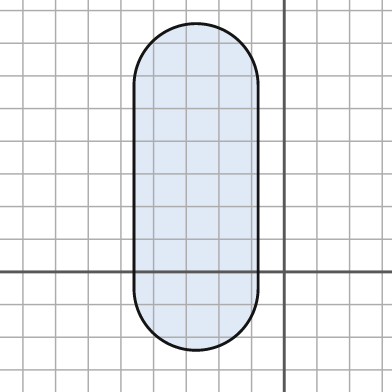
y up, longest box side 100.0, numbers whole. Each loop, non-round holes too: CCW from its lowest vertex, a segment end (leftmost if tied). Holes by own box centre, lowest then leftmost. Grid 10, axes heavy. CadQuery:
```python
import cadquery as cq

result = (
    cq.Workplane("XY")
    .moveTo(-46.0, -5.0)
    .threePointArc((-27.0, -24.0), (-8.0, -5.0))
    .lineTo(-8.0, 57.0)
    .threePointArc((-27.0, 76.0), (-46.0, 57.0))
    .close()
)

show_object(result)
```